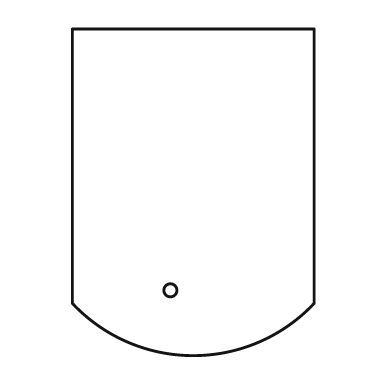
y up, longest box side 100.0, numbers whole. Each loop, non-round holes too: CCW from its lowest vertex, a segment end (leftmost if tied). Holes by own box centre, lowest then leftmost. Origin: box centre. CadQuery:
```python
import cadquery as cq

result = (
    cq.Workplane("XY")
    .moveTo(-37.0, -34.0)
    .threePointArc((0.0, -50.0), (37.0, -34.0))
    .lineTo(37.0, 50.0)
    .lineTo(-37.0, 50.0)
    .close()
    .moveTo(-7.0, -30.0)
    .circle(2.0)
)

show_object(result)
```